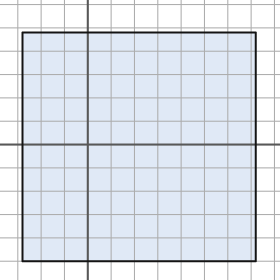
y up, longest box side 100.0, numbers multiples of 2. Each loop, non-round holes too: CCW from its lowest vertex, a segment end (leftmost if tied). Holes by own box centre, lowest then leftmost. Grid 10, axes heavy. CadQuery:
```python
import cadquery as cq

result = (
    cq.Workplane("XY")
    .moveTo(-28.0, -50.0)
    .lineTo(72.0, -50.0)
    .lineTo(72.0, 48.0)
    .lineTo(-28.0, 48.0)
    .close()
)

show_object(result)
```